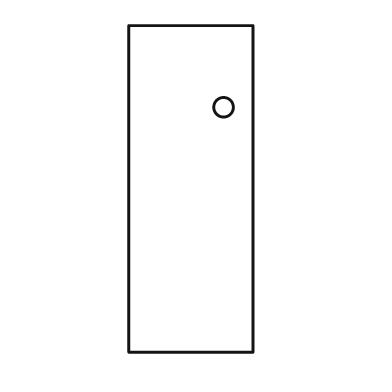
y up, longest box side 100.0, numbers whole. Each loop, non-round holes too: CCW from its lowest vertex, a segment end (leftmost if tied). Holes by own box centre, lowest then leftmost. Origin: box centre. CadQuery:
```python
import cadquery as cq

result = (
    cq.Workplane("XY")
    .moveTo(-19.0, -50.0)
    .lineTo(19.0, -50.0)
    .lineTo(19.0, 50.0)
    .lineTo(-19.0, 50.0)
    .close()
    .moveTo(10.0, 25.0)
    .circle(3.0)
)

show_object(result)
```